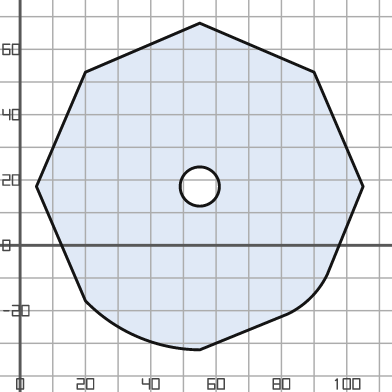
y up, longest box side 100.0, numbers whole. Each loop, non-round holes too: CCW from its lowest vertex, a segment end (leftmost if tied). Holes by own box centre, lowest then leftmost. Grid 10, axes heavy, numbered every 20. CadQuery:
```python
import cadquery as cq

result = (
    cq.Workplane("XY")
    .moveTo(55.0, -32.0)
    .lineTo(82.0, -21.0)
    .threePointArc((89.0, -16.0), (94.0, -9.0))
    .lineTo(105.0, 18.0)
    .lineTo(90.0, 53.0)
    .lineTo(55.0, 68.0)
    .lineTo(20.0, 53.0)
    .lineTo(5.0, 18.0)
    .lineTo(20.0, -17.0)
    .threePointArc((36.0, -28.0), (55.0, -32.0))
    .close()
    .moveTo(55.0, 18.0)
    .circle(6.0)
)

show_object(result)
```